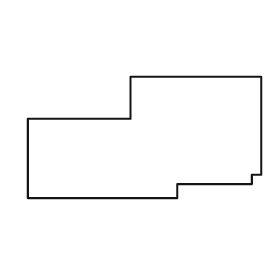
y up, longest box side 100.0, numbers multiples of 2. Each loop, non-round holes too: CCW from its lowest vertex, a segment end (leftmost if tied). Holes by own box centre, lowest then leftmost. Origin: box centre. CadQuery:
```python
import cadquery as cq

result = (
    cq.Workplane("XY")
    .moveTo(-50.0, -26.0)
    .lineTo(14.0, -26.0)
    .lineTo(14.0, -20.0)
    .lineTo(46.0, -20.0)
    .lineTo(46.0, -16.0)
    .lineTo(50.0, -16.0)
    .lineTo(50.0, 26.0)
    .lineTo(-6.0, 26.0)
    .lineTo(-6.0, 8.0)
    .lineTo(-50.0, 8.0)
    .close()
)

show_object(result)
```